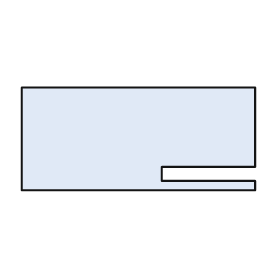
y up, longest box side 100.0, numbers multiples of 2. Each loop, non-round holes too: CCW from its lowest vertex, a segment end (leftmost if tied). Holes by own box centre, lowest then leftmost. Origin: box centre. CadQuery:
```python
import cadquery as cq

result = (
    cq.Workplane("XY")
    .moveTo(-50.0, -22.0)
    .lineTo(50.0, -22.0)
    .lineTo(50.0, -18.0)
    .lineTo(10.0, -18.0)
    .lineTo(10.0, -12.0)
    .lineTo(50.0, -12.0)
    .lineTo(50.0, 22.0)
    .lineTo(-50.0, 22.0)
    .close()
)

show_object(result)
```